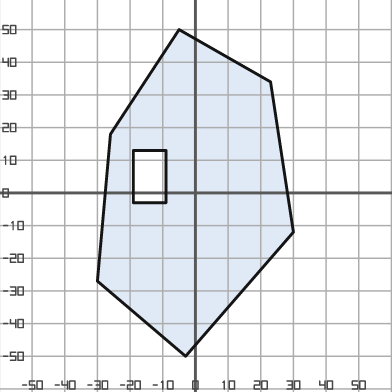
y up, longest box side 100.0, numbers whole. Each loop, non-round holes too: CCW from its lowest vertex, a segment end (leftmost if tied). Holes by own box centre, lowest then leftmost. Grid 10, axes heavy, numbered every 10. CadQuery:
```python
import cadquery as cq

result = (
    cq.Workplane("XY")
    .moveTo(-3.0, -50.0)
    .lineTo(30.0, -12.0)
    .lineTo(23.0, 34.0)
    .lineTo(-5.0, 50.0)
    .lineTo(-26.0, 18.0)
    .lineTo(-30.0, -27.0)
    .close()
    .moveTo(-19.0, -3.0)
    .lineTo(-9.0, -3.0)
    .lineTo(-9.0, 13.0)
    .lineTo(-19.0, 13.0)
    .close()
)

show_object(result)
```